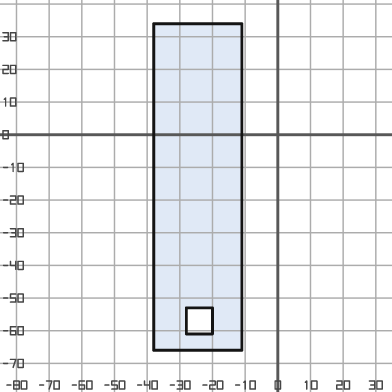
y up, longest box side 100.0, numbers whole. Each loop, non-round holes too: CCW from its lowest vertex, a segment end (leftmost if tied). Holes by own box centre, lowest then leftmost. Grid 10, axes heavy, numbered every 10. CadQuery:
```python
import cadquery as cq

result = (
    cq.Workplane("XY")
    .moveTo(-38.0, -66.0)
    .lineTo(-11.0, -66.0)
    .lineTo(-11.0, 34.0)
    .lineTo(-38.0, 34.0)
    .close()
    .moveTo(-28.0, -61.0)
    .lineTo(-20.0, -61.0)
    .lineTo(-20.0, -53.0)
    .lineTo(-28.0, -53.0)
    .close()
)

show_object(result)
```